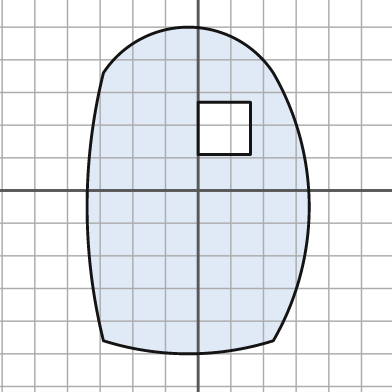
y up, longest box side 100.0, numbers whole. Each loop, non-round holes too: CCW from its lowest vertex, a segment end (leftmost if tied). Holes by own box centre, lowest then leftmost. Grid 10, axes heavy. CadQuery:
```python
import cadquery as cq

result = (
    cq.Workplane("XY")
    .moveTo(-29.0, -46.0)
    .threePointArc((-3.0, -50.0), (23.0, -46.0))
    .threePointArc((34.0, -5.0), (23.0, 36.0))
    .threePointArc((-3.0, 50.0), (-29.0, 36.0))
    .threePointArc((-34.0, -5.0), (-29.0, -46.0))
    .close()
    .moveTo(0.0, 11.0)
    .lineTo(16.0, 11.0)
    .lineTo(16.0, 27.0)
    .lineTo(0.0, 27.0)
    .close()
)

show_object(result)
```